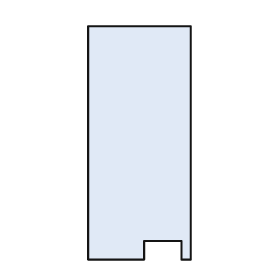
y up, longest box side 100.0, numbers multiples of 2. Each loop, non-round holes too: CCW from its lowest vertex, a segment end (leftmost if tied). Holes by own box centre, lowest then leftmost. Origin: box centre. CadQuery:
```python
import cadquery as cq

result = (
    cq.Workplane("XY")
    .moveTo(-22.0, -50.0)
    .lineTo(2.0, -50.0)
    .lineTo(2.0, -42.0)
    .lineTo(18.0, -42.0)
    .lineTo(18.0, -50.0)
    .lineTo(22.0, -50.0)
    .lineTo(22.0, 50.0)
    .lineTo(-22.0, 50.0)
    .close()
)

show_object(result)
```